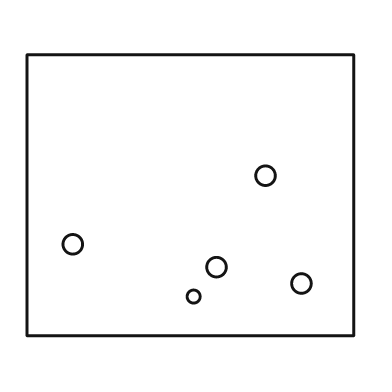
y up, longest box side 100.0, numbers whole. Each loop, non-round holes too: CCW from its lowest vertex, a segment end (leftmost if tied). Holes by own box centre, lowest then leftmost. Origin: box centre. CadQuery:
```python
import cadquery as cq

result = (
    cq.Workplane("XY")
    .moveTo(-50.0, -43.0)
    .lineTo(50.0, -43.0)
    .lineTo(50.0, 43.0)
    .lineTo(-50.0, 43.0)
    .close()
    .moveTo(1.0, -31.0)
    .circle(2.0)
    .moveTo(34.0, -27.0)
    .circle(3.0)
    .moveTo(8.0, -22.0)
    .circle(3.0)
    .moveTo(-36.0, -15.0)
    .circle(3.0)
    .moveTo(23.0, 6.0)
    .circle(3.0)
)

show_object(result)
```